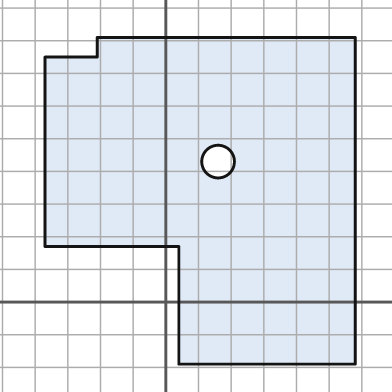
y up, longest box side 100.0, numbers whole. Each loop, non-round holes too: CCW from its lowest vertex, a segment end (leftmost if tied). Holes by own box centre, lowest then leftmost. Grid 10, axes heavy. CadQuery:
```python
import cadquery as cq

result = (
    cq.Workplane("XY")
    .moveTo(4.0, -19.0)
    .lineTo(58.0, -19.0)
    .lineTo(58.0, 81.0)
    .lineTo(-21.0, 81.0)
    .lineTo(-21.0, 75.0)
    .lineTo(-37.0, 75.0)
    .lineTo(-37.0, 17.0)
    .lineTo(4.0, 17.0)
    .close()
    .moveTo(16.0, 43.0)
    .circle(5.0)
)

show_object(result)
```